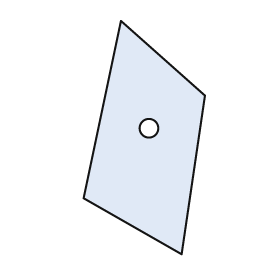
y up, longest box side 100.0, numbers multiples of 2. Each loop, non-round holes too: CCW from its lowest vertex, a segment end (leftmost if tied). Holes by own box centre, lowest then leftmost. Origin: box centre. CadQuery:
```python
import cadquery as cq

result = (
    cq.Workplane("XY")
    .moveTo(16.0, -50.0)
    .lineTo(26.0, 18.0)
    .lineTo(-10.0, 50.0)
    .lineTo(-26.0, -26.0)
    .close()
    .moveTo(2.0, 4.0)
    .circle(4.0)
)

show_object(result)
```